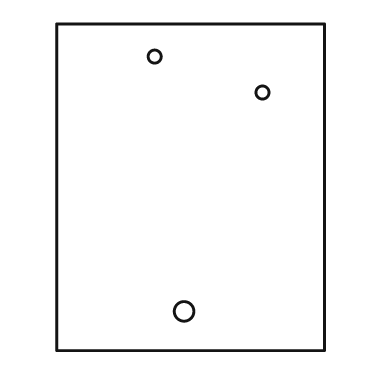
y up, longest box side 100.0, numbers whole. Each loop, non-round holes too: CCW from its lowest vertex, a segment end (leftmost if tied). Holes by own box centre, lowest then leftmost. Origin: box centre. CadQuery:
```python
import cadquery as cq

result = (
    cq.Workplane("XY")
    .moveTo(-41.0, -50.0)
    .lineTo(41.0, -50.0)
    .lineTo(41.0, 50.0)
    .lineTo(-41.0, 50.0)
    .close()
    .moveTo(-2.0, -38.0)
    .circle(3.0)
    .moveTo(22.0, 29.0)
    .circle(2.0)
    .moveTo(-11.0, 40.0)
    .circle(2.0)
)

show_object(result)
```